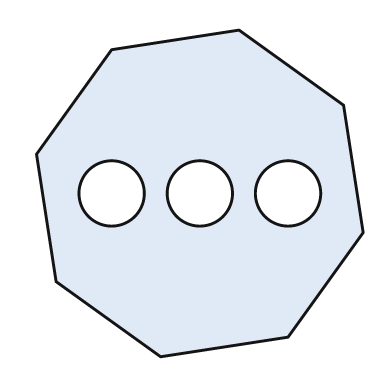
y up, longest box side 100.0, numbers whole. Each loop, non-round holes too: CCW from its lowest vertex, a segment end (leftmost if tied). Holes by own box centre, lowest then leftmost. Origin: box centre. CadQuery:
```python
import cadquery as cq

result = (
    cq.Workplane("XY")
    .moveTo(-12.0, -50.0)
    .lineTo(27.0, -44.0)
    .lineTo(50.0, -12.0)
    .lineTo(44.0, 27.0)
    .lineTo(12.0, 50.0)
    .lineTo(-27.0, 44.0)
    .lineTo(-50.0, 12.0)
    .lineTo(-44.0, -27.0)
    .close()
    .moveTo(-27.0, 0.0)
    .circle(10.0)
    .moveTo(0.0, 0.0)
    .circle(10.0)
    .moveTo(27.0, 0.0)
    .circle(10.0)
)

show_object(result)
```